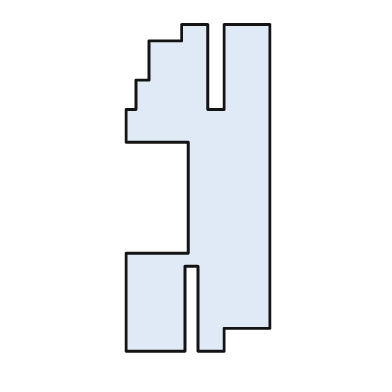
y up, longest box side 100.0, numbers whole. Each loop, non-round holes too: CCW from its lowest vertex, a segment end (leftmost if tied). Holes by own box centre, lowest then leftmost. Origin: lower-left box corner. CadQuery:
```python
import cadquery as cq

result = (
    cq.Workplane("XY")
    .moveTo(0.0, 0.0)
    .lineTo(18.0, 0.0)
    .lineTo(18.0, 26.0)
    .lineTo(22.0, 26.0)
    .lineTo(22.0, 0.0)
    .lineTo(30.0, 0.0)
    .lineTo(30.0, 7.0)
    .lineTo(44.0, 7.0)
    .lineTo(44.0, 100.0)
    .lineTo(30.0, 100.0)
    .lineTo(30.0, 74.0)
    .lineTo(25.0, 74.0)
    .lineTo(25.0, 100.0)
    .lineTo(17.0, 100.0)
    .lineTo(17.0, 95.0)
    .lineTo(7.0, 95.0)
    .lineTo(7.0, 83.0)
    .lineTo(3.0, 83.0)
    .lineTo(3.0, 74.0)
    .lineTo(0.0, 74.0)
    .lineTo(0.0, 64.0)
    .lineTo(19.0, 64.0)
    .lineTo(19.0, 30.0)
    .lineTo(0.0, 30.0)
    .close()
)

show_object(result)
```